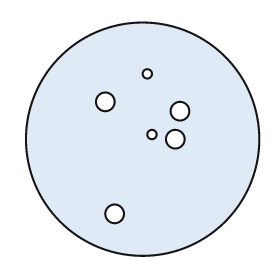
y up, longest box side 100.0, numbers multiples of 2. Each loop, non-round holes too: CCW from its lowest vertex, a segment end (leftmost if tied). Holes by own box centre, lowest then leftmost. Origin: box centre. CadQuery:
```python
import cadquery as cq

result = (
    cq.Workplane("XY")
    .moveTo(0.0, 0.0)
    .circle(50.0)
    .moveTo(-12.0, -32.0)
    .circle(4.0)
    .moveTo(14.0, 0.0)
    .circle(4.0)
    .moveTo(4.0, 2.0)
    .circle(2.0)
    .moveTo(16.0, 12.0)
    .circle(4.0)
    .moveTo(-16.0, 16.0)
    .circle(4.0)
    .moveTo(2.0, 28.0)
    .circle(2.0)
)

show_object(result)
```